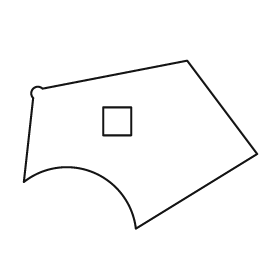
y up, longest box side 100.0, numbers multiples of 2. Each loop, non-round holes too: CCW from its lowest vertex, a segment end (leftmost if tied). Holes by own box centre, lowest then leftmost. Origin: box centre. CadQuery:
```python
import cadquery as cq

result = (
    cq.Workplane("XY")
    .moveTo(-2.0, -36.0)
    .lineTo(50.0, -4.0)
    .lineTo(20.0, 36.0)
    .lineTo(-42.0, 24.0)
    .threePointArc((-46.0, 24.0), (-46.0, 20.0))
    .lineTo(-50.0, -16.0)
    .threePointArc((-20.0, -12.0), (-2.0, -36.0))
    .close()
    .moveTo(-16.0, 4.0)
    .lineTo(-4.0, 4.0)
    .lineTo(-4.0, 16.0)
    .lineTo(-16.0, 16.0)
    .close()
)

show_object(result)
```